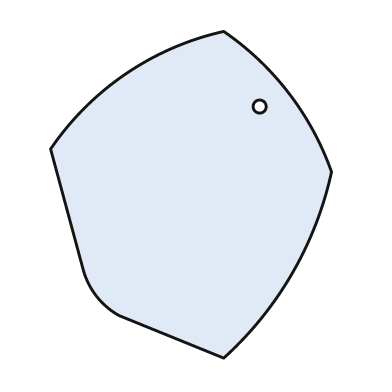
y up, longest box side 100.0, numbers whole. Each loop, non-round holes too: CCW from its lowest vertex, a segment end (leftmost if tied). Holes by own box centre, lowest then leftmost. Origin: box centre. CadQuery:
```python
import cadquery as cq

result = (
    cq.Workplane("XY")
    .moveTo(10.0, -50.0)
    .threePointArc((31.0, -24.0), (43.0, 7.0))
    .threePointArc((30.0, 31.0), (10.0, 50.0))
    .threePointArc((-20.0, 37.0), (-43.0, 14.0))
    .lineTo(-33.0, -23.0)
    .threePointArc((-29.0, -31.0), (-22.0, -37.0))
    .close()
    .moveTo(21.0, 27.0)
    .circle(2.0)
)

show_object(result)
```